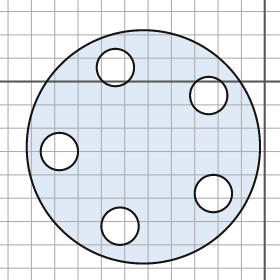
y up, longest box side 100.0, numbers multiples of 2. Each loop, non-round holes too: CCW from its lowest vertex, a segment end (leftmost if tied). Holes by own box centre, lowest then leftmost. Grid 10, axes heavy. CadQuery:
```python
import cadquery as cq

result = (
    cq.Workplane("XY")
    .moveTo(-52.0, -28.0)
    .circle(50.0)
    .moveTo(-62.0, -62.0)
    .circle(8.0)
    .moveTo(-22.0, -48.0)
    .circle(8.0)
    .moveTo(-88.0, -30.0)
    .circle(8.0)
    .moveTo(-24.0, -6.0)
    .circle(8.0)
    .moveTo(-64.0, 6.0)
    .circle(8.0)
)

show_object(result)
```